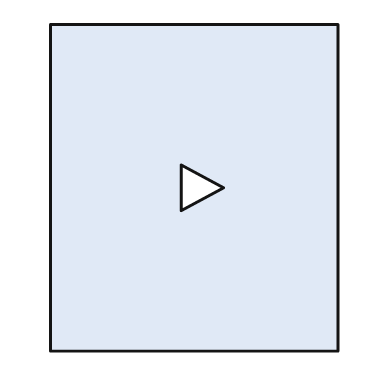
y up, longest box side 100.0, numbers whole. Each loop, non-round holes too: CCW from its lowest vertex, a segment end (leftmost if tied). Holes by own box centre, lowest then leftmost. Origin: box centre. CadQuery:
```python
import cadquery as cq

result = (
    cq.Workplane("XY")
    .moveTo(-44.0, -50.0)
    .lineTo(44.0, -50.0)
    .lineTo(44.0, 50.0)
    .lineTo(-44.0, 50.0)
    .close()
    .moveTo(-4.0, -7.0)
    .lineTo(9.0, 0.0)
    .lineTo(-4.0, 7.0)
    .close()
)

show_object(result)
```